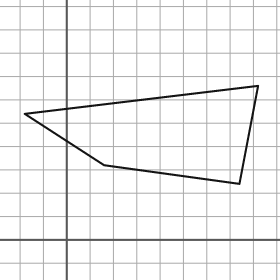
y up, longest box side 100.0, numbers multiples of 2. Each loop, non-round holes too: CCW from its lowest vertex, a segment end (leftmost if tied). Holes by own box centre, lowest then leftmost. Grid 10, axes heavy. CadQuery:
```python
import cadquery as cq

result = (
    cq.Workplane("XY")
    .moveTo(74.0, 24.0)
    .lineTo(82.0, 66.0)
    .lineTo(-18.0, 54.0)
    .lineTo(16.0, 32.0)
    .close()
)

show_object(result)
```